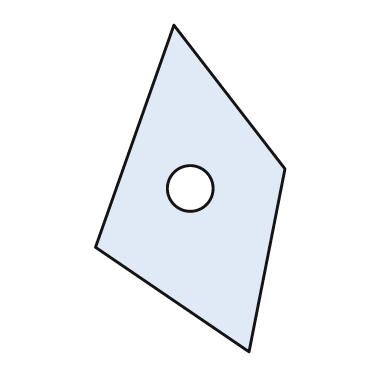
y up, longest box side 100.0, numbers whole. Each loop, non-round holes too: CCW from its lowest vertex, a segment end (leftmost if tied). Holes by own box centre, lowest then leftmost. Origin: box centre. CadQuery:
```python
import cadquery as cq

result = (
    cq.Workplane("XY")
    .moveTo(18.0, -50.0)
    .lineTo(29.0, 6.0)
    .lineTo(-5.0, 50.0)
    .lineTo(-29.0, -18.0)
    .close()
    .moveTo(0.0, 0.0)
    .circle(7.0)
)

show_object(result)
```